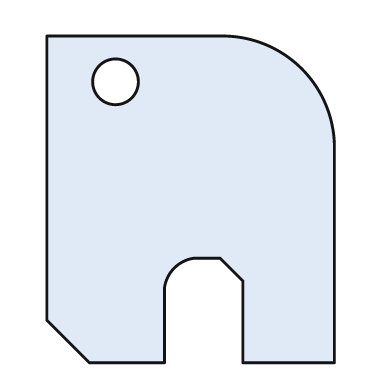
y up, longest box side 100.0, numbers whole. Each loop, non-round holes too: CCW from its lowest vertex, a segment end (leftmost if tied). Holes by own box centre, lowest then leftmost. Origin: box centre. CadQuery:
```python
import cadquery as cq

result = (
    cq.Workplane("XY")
    .moveTo(-31.0, -50.0)
    .lineTo(-8.0, -50.0)
    .lineTo(-8.0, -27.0)
    .threePointArc((-5.0, -21.0), (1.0, -18.0))
    .lineTo(9.0, -18.0)
    .lineTo(16.0, -25.0)
    .lineTo(16.0, -50.0)
    .lineTo(44.0, -50.0)
    .lineTo(44.0, 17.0)
    .threePointArc((34.0, 40.0), (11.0, 50.0))
    .lineTo(-44.0, 50.0)
    .lineTo(-44.0, -37.0)
    .close()
    .moveTo(-23.0, 36.0)
    .circle(7.0)
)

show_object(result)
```